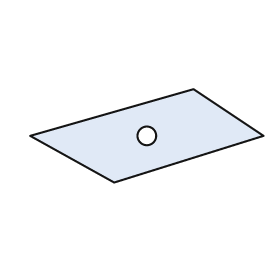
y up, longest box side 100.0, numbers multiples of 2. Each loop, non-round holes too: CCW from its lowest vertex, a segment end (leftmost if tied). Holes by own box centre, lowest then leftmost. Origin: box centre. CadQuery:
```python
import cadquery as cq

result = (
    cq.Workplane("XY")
    .moveTo(-14.0, -20.0)
    .lineTo(50.0, 0.0)
    .lineTo(20.0, 20.0)
    .lineTo(-50.0, 0.0)
    .close()
    .moveTo(0.0, 0.0)
    .circle(4.0)
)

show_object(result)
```